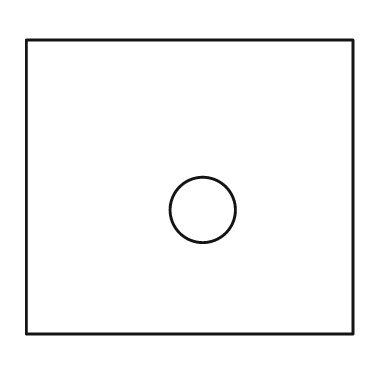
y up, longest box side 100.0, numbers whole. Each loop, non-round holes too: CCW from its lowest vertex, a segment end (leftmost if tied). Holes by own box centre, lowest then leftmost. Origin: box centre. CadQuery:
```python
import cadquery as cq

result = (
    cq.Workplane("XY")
    .moveTo(-50.0, -45.0)
    .lineTo(50.0, -45.0)
    .lineTo(50.0, 45.0)
    .lineTo(-50.0, 45.0)
    .close()
    .moveTo(4.0, -7.0)
    .circle(10.0)
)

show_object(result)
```